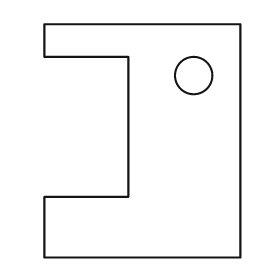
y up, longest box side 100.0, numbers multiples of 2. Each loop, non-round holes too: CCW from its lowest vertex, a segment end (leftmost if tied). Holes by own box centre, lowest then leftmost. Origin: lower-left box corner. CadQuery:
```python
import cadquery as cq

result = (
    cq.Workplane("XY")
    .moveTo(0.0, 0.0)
    .lineTo(84.0, 0.0)
    .lineTo(84.0, 100.0)
    .lineTo(0.0, 100.0)
    .lineTo(0.0, 86.0)
    .lineTo(36.0, 86.0)
    .lineTo(36.0, 26.0)
    .lineTo(0.0, 26.0)
    .close()
    .moveTo(64.0, 78.0)
    .circle(8.0)
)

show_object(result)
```